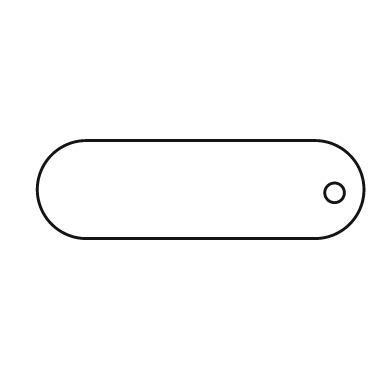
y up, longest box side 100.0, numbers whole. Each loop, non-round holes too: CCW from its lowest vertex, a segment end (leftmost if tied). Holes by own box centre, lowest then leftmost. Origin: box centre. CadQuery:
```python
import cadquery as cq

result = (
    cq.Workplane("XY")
    .moveTo(-35.0, -15.0)
    .lineTo(35.0, -15.0)
    .threePointArc((50.0, 0.0), (35.0, 15.0))
    .lineTo(-35.0, 15.0)
    .threePointArc((-50.0, 0.0), (-35.0, -15.0))
    .close()
    .moveTo(41.0, -1.0)
    .circle(3.0)
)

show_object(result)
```